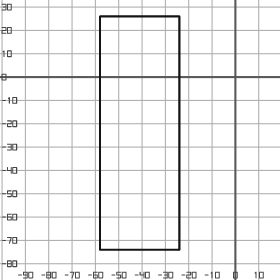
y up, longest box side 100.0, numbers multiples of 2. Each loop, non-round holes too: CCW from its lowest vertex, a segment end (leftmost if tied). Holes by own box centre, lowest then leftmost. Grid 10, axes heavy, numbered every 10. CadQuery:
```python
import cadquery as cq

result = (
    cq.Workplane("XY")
    .moveTo(-58.0, -74.0)
    .lineTo(-24.0, -74.0)
    .lineTo(-24.0, 26.0)
    .lineTo(-58.0, 26.0)
    .close()
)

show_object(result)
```